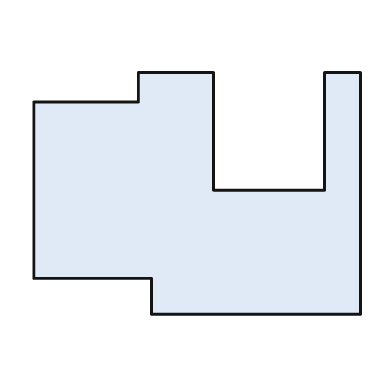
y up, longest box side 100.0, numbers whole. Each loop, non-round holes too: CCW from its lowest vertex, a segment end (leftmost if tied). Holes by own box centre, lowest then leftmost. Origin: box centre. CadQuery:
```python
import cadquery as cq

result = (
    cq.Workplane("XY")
    .moveTo(-14.0, -37.0)
    .lineTo(50.0, -37.0)
    .lineTo(50.0, 37.0)
    .lineTo(39.0, 37.0)
    .lineTo(39.0, 1.0)
    .lineTo(5.0, 1.0)
    .lineTo(5.0, 37.0)
    .lineTo(-18.0, 37.0)
    .lineTo(-18.0, 28.0)
    .lineTo(-50.0, 28.0)
    .lineTo(-50.0, -26.0)
    .lineTo(-14.0, -26.0)
    .close()
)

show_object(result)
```